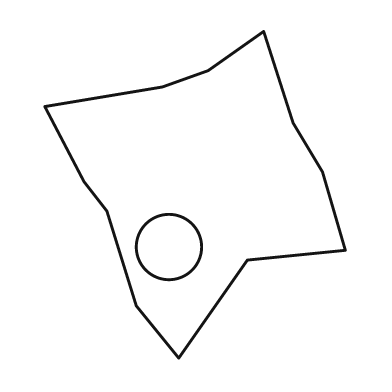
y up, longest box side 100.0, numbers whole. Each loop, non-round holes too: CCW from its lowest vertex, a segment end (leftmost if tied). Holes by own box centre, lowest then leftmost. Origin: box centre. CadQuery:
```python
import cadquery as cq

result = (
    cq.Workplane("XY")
    .moveTo(-5.0, -50.0)
    .lineTo(16.0, -20.0)
    .lineTo(46.0, -17.0)
    .lineTo(39.0, 7.0)
    .lineTo(30.0, 22.0)
    .lineTo(21.0, 50.0)
    .lineTo(4.0, 38.0)
    .lineTo(-10.0, 33.0)
    .lineTo(-46.0, 27.0)
    .lineTo(-34.0, 4.0)
    .lineTo(-27.0, -5.0)
    .lineTo(-18.0, -34.0)
    .close()
    .moveTo(-8.0, -16.0)
    .circle(10.0)
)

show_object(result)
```